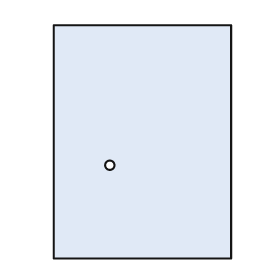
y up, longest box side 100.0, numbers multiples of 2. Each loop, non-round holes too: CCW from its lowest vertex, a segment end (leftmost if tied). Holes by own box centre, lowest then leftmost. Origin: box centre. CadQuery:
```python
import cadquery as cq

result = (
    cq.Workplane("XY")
    .moveTo(-38.0, -50.0)
    .lineTo(38.0, -50.0)
    .lineTo(38.0, 50.0)
    .lineTo(-38.0, 50.0)
    .close()
    .moveTo(-14.0, -10.0)
    .circle(2.0)
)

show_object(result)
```